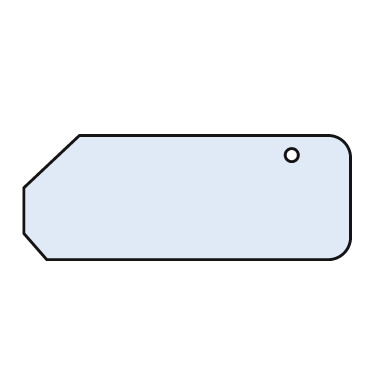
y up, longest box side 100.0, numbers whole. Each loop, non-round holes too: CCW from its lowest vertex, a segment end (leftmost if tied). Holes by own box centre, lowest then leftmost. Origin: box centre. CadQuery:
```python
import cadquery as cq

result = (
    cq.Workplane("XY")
    .moveTo(-43.0, -19.0)
    .lineTo(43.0, -19.0)
    .threePointArc((48.0, -17.0), (50.0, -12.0))
    .lineTo(50.0, 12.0)
    .threePointArc((48.0, 17.0), (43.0, 19.0))
    .lineTo(-33.0, 19.0)
    .lineTo(-50.0, 3.0)
    .lineTo(-50.0, -11.0)
    .close()
    .moveTo(32.0, 13.0)
    .circle(2.0)
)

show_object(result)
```